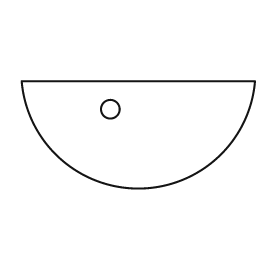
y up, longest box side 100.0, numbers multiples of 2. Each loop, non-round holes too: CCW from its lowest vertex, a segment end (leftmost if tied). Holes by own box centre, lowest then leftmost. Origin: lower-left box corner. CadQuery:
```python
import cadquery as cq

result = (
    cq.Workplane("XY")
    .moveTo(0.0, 46.0)
    .threePointArc((50.0, 0.0), (100.0, 46.0))
    .close()
    .moveTo(38.0, 34.0)
    .circle(4.0)
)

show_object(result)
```